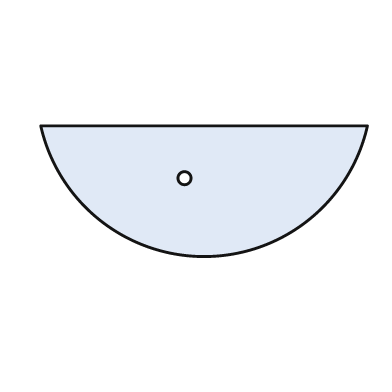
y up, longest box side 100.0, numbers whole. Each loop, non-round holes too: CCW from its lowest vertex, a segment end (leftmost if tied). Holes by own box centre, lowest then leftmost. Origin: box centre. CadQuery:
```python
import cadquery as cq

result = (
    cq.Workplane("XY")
    .moveTo(-50.0, 20.0)
    .threePointArc((0.0, -20.0), (50.0, 20.0))
    .close()
    .moveTo(-6.0, 4.0)
    .circle(2.0)
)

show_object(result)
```